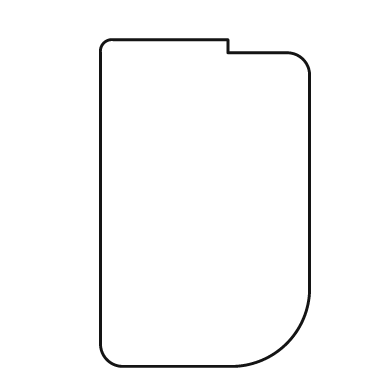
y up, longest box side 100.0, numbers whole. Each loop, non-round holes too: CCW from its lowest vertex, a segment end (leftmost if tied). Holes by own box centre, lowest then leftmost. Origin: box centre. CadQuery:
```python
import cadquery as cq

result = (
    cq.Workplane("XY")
    .moveTo(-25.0, -50.0)
    .lineTo(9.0, -50.0)
    .threePointArc((25.0, -43.0), (32.0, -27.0))
    .lineTo(32.0, 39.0)
    .threePointArc((30.0, 44.0), (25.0, 46.0))
    .lineTo(7.0, 46.0)
    .lineTo(7.0, 50.0)
    .lineTo(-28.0, 50.0)
    .threePointArc((-31.0, 49.0), (-32.0, 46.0))
    .lineTo(-32.0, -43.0)
    .threePointArc((-30.0, -48.0), (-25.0, -50.0))
    .close()
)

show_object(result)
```